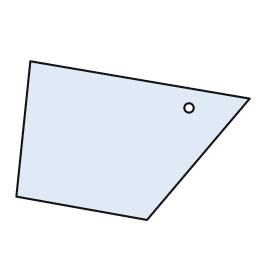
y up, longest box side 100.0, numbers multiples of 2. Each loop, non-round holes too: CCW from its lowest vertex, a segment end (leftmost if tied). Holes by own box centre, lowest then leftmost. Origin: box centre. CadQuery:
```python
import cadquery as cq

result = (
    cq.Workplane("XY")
    .moveTo(6.0, -34.0)
    .lineTo(50.0, 18.0)
    .lineTo(-44.0, 34.0)
    .lineTo(-50.0, -24.0)
    .close()
    .moveTo(24.0, 14.0)
    .circle(2.0)
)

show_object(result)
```